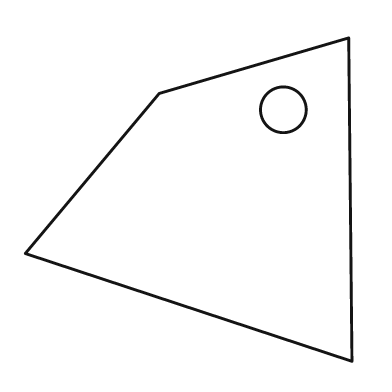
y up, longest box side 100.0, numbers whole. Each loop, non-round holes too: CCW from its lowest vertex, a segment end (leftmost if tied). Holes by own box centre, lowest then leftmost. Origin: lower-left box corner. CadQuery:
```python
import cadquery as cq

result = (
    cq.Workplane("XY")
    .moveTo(100.0, 0.0)
    .lineTo(99.0, 99.0)
    .lineTo(41.0, 82.0)
    .lineTo(0.0, 33.0)
    .close()
    .moveTo(79.0, 77.0)
    .circle(7.0)
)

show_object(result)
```